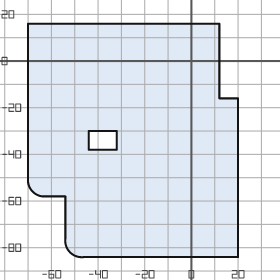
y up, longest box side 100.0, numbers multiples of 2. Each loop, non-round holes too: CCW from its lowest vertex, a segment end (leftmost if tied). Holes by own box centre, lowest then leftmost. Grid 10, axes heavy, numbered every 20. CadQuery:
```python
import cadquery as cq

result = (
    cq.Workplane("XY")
    .moveTo(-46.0, -84.0)
    .lineTo(20.0, -84.0)
    .lineTo(20.0, -16.0)
    .lineTo(12.0, -16.0)
    .lineTo(12.0, 16.0)
    .lineTo(-70.0, 16.0)
    .lineTo(-70.0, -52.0)
    .threePointArc((-68.0, -56.0), (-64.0, -58.0))
    .lineTo(-54.0, -58.0)
    .lineTo(-54.0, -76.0)
    .threePointArc((-52.0, -82.0), (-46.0, -84.0))
    .close()
    .moveTo(-44.0, -38.0)
    .lineTo(-32.0, -38.0)
    .lineTo(-32.0, -30.0)
    .lineTo(-44.0, -30.0)
    .close()
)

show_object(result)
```